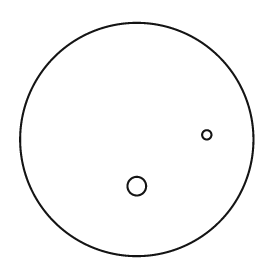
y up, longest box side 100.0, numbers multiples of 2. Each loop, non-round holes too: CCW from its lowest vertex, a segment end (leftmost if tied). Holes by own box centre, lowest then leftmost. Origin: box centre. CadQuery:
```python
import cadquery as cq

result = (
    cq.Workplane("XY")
    .moveTo(0.0, 0.0)
    .circle(50.0)
    .moveTo(0.0, -20.0)
    .circle(4.0)
    .moveTo(30.0, 2.0)
    .circle(2.0)
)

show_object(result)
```